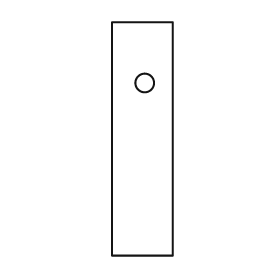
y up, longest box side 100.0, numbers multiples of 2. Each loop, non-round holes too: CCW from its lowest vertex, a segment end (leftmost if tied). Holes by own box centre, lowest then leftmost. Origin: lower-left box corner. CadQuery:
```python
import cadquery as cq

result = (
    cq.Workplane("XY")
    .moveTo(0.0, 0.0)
    .lineTo(26.0, 0.0)
    .lineTo(26.0, 100.0)
    .lineTo(0.0, 100.0)
    .close()
    .moveTo(14.0, 74.0)
    .circle(4.0)
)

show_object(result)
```